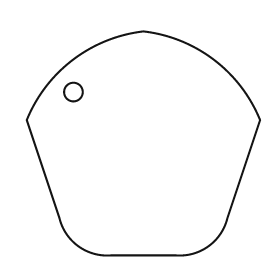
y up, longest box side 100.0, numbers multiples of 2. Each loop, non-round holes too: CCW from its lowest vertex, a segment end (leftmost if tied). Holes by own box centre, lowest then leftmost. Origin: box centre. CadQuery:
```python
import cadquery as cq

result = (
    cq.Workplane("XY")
    .moveTo(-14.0, -48.0)
    .lineTo(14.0, -48.0)
    .threePointArc((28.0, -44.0), (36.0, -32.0))
    .lineTo(50.0, 10.0)
    .threePointArc((30.0, 36.0), (0.0, 48.0))
    .threePointArc((-30.0, 36.0), (-50.0, 10.0))
    .lineTo(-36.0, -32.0)
    .threePointArc((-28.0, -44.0), (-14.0, -48.0))
    .close()
    .moveTo(-30.0, 22.0)
    .circle(4.0)
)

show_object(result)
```